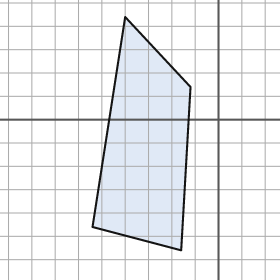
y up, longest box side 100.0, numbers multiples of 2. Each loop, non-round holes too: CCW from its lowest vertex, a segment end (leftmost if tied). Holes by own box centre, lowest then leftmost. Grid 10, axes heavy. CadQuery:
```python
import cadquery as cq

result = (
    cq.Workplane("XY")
    .moveTo(-16.0, -56.0)
    .lineTo(-12.0, 14.0)
    .lineTo(-40.0, 44.0)
    .lineTo(-54.0, -46.0)
    .close()
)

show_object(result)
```